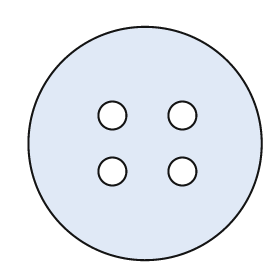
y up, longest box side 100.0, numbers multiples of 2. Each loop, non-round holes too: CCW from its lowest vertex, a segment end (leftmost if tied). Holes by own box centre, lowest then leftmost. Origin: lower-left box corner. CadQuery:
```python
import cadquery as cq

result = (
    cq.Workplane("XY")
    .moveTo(50.0, 50.0)
    .circle(50.0)
    .moveTo(36.0, 38.0)
    .circle(6.0)
    .moveTo(66.0, 38.0)
    .circle(6.0)
    .moveTo(36.0, 62.0)
    .circle(6.0)
    .moveTo(66.0, 62.0)
    .circle(6.0)
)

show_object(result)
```